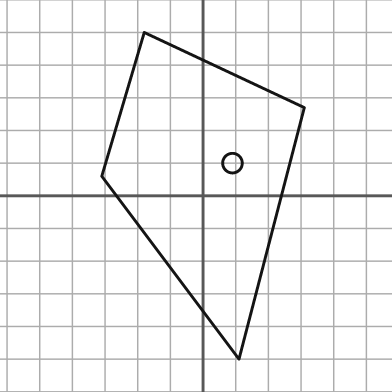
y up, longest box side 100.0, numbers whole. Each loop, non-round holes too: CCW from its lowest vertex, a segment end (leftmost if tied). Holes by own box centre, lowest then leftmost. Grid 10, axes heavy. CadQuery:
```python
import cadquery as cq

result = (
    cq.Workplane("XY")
    .moveTo(11.0, -50.0)
    .lineTo(31.0, 27.0)
    .lineTo(-18.0, 50.0)
    .lineTo(-31.0, 6.0)
    .close()
    .moveTo(9.0, 10.0)
    .circle(3.0)
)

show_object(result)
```